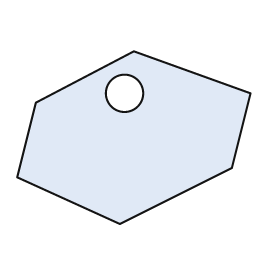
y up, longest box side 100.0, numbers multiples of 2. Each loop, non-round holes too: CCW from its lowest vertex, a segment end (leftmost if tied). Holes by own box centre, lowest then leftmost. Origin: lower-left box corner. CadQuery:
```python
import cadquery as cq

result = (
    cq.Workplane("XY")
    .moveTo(44.0, 0.0)
    .lineTo(92.0, 24.0)
    .lineTo(100.0, 56.0)
    .lineTo(50.0, 74.0)
    .lineTo(8.0, 52.0)
    .lineTo(0.0, 20.0)
    .close()
    .moveTo(46.0, 56.0)
    .circle(8.0)
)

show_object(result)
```